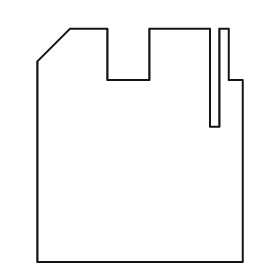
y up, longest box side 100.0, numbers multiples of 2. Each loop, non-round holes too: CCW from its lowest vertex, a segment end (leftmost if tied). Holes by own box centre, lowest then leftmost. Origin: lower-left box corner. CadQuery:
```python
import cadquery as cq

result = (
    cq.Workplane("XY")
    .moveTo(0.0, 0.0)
    .lineTo(88.0, 0.0)
    .lineTo(88.0, 78.0)
    .lineTo(82.0, 78.0)
    .lineTo(82.0, 100.0)
    .lineTo(78.0, 100.0)
    .lineTo(78.0, 58.0)
    .lineTo(74.0, 58.0)
    .lineTo(74.0, 100.0)
    .lineTo(48.0, 100.0)
    .lineTo(48.0, 78.0)
    .lineTo(30.0, 78.0)
    .lineTo(30.0, 100.0)
    .lineTo(14.0, 100.0)
    .lineTo(0.0, 86.0)
    .close()
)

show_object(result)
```